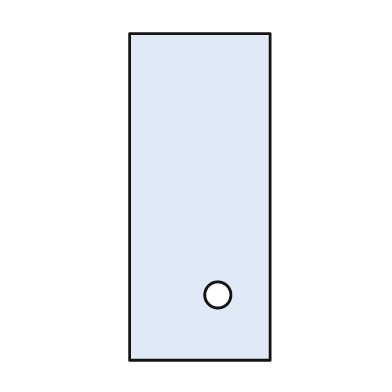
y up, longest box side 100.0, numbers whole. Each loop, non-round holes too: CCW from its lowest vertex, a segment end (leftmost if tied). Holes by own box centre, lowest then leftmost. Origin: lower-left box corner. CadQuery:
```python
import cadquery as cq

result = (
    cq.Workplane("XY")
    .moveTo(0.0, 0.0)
    .lineTo(43.0, 0.0)
    .lineTo(43.0, 100.0)
    .lineTo(0.0, 100.0)
    .close()
    .moveTo(27.0, 20.0)
    .circle(4.0)
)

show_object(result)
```